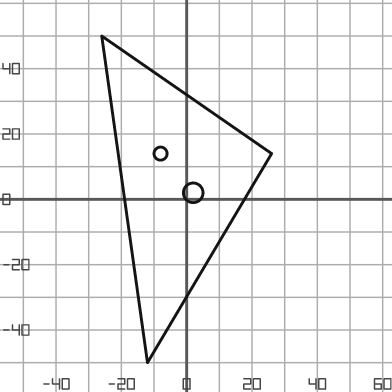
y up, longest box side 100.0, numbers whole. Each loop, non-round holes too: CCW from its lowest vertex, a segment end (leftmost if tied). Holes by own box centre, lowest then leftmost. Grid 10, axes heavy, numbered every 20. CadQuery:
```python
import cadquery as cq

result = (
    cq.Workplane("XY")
    .moveTo(-12.0, -50.0)
    .lineTo(26.0, 14.0)
    .lineTo(-26.0, 50.0)
    .close()
    .moveTo(2.0, 2.0)
    .circle(3.0)
    .moveTo(-8.0, 14.0)
    .circle(2.0)
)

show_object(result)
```